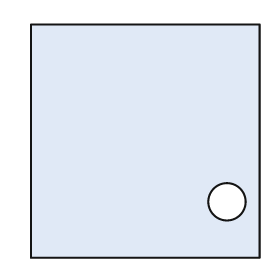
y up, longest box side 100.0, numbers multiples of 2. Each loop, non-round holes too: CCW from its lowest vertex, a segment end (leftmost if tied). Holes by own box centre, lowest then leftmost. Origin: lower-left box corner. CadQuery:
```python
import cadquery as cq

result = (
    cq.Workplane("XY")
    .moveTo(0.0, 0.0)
    .lineTo(98.0, 0.0)
    .lineTo(98.0, 100.0)
    .lineTo(0.0, 100.0)
    .close()
    .moveTo(84.0, 24.0)
    .circle(8.0)
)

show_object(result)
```